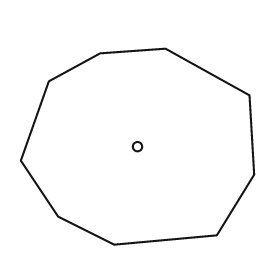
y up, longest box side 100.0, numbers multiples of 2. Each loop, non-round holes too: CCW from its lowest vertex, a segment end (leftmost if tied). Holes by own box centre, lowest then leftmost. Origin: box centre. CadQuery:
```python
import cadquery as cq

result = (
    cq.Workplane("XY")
    .moveTo(-10.0, -42.0)
    .lineTo(34.0, -38.0)
    .lineTo(50.0, -12.0)
    .lineTo(48.0, 22.0)
    .lineTo(12.0, 42.0)
    .lineTo(-16.0, 40.0)
    .lineTo(-38.0, 28.0)
    .lineTo(-50.0, -6.0)
    .lineTo(-34.0, -30.0)
    .close()
    .moveTo(0.0, 0.0)
    .circle(2.0)
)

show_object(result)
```